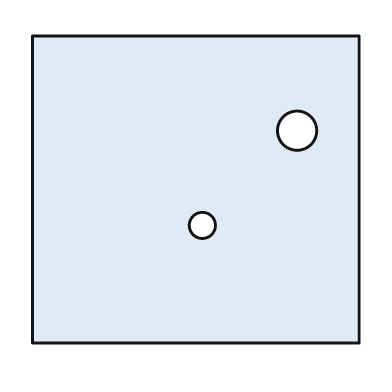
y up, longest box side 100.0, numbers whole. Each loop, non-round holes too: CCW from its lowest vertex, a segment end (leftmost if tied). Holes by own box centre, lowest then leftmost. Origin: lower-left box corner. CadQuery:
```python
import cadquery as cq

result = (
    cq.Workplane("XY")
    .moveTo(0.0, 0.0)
    .lineTo(100.0, 0.0)
    .lineTo(100.0, 94.0)
    .lineTo(0.0, 94.0)
    .close()
    .moveTo(52.0, 36.0)
    .circle(4.0)
    .moveTo(81.0, 65.0)
    .circle(6.0)
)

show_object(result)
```